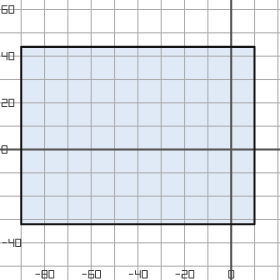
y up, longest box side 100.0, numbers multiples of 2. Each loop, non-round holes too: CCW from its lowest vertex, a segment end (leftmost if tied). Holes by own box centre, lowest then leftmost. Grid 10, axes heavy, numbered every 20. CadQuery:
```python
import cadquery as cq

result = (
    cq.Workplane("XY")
    .moveTo(-90.0, -32.0)
    .lineTo(10.0, -32.0)
    .lineTo(10.0, 44.0)
    .lineTo(-90.0, 44.0)
    .close()
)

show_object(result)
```